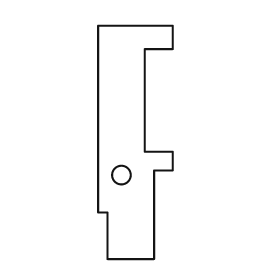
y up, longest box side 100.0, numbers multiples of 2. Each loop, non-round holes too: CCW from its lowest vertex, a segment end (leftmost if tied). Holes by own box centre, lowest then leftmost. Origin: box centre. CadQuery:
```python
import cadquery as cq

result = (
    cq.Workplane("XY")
    .moveTo(-12.0, -50.0)
    .lineTo(8.0, -50.0)
    .lineTo(8.0, -12.0)
    .lineTo(16.0, -12.0)
    .lineTo(16.0, -4.0)
    .lineTo(4.0, -4.0)
    .lineTo(4.0, 40.0)
    .lineTo(16.0, 40.0)
    .lineTo(16.0, 50.0)
    .lineTo(-16.0, 50.0)
    .lineTo(-16.0, -30.0)
    .lineTo(-12.0, -30.0)
    .close()
    .moveTo(-6.0, -14.0)
    .circle(4.0)
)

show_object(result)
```